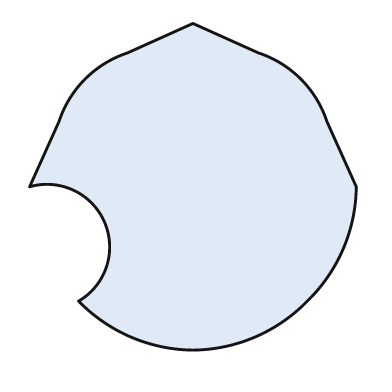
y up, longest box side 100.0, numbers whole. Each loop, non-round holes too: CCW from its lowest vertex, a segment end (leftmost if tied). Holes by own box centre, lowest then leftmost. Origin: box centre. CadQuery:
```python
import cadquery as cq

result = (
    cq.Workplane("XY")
    .moveTo(0.0, -50.0)
    .threePointArc((19.0, -46.0), (35.0, -35.0))
    .threePointArc((46.0, -19.0), (50.0, 0.0))
    .lineTo(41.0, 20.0)
    .threePointArc((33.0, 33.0), (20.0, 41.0))
    .lineTo(0.0, 50.0)
    .lineTo(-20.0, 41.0)
    .threePointArc((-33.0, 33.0), (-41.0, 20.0))
    .lineTo(-50.0, 0.0)
    .threePointArc((-27.0, -11.0), (-35.0, -35.0))
    .threePointArc((-19.0, -46.0), (0.0, -50.0))
    .close()
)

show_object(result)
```